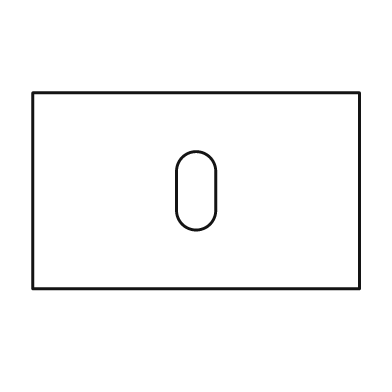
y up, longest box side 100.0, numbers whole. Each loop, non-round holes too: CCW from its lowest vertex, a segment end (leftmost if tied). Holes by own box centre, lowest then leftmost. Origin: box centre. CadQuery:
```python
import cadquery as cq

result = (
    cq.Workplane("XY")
    .moveTo(-50.0, -30.0)
    .lineTo(50.0, -30.0)
    .lineTo(50.0, 30.0)
    .lineTo(-50.0, 30.0)
    .close()
    .moveTo(-6.0, -6.0)
    .threePointArc((0.0, -12.0), (6.0, -6.0))
    .lineTo(6.0, 6.0)
    .threePointArc((0.0, 12.0), (-6.0, 6.0))
    .close()
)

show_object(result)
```